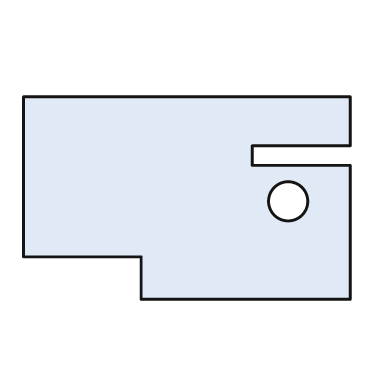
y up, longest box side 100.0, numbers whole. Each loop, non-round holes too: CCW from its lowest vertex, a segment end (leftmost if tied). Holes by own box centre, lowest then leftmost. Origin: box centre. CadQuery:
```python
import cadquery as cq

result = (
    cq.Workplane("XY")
    .moveTo(-14.0, -31.0)
    .lineTo(50.0, -31.0)
    .lineTo(50.0, 10.0)
    .lineTo(20.0, 10.0)
    .lineTo(20.0, 16.0)
    .lineTo(50.0, 16.0)
    .lineTo(50.0, 31.0)
    .lineTo(-50.0, 31.0)
    .lineTo(-50.0, -18.0)
    .lineTo(-14.0, -18.0)
    .close()
    .moveTo(31.0, -1.0)
    .circle(6.0)
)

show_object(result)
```